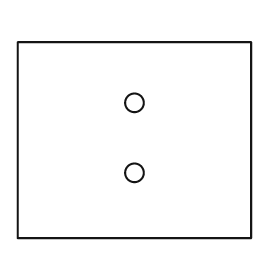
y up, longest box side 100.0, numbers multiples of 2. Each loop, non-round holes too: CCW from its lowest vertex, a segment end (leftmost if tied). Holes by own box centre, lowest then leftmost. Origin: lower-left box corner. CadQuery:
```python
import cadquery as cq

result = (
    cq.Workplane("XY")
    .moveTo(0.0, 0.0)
    .lineTo(100.0, 0.0)
    .lineTo(100.0, 84.0)
    .lineTo(0.0, 84.0)
    .close()
    .moveTo(50.0, 28.0)
    .circle(4.0)
    .moveTo(50.0, 58.0)
    .circle(4.0)
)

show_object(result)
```